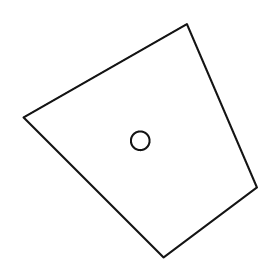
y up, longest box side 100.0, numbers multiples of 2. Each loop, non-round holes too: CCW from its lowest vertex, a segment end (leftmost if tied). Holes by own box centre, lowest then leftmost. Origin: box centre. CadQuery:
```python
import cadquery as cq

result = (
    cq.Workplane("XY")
    .moveTo(10.0, -50.0)
    .lineTo(50.0, -20.0)
    .lineTo(20.0, 50.0)
    .lineTo(-50.0, 10.0)
    .close()
    .moveTo(0.0, 0.0)
    .circle(4.0)
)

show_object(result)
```